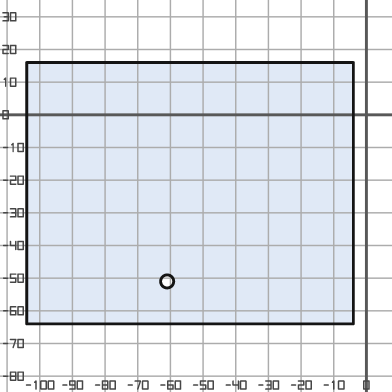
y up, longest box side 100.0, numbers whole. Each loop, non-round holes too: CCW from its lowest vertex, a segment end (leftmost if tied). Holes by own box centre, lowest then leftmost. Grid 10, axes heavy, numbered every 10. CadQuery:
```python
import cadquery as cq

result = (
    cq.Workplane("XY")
    .moveTo(-104.0, -64.0)
    .lineTo(-4.0, -64.0)
    .lineTo(-4.0, 16.0)
    .lineTo(-104.0, 16.0)
    .close()
    .moveTo(-61.0, -51.0)
    .circle(2.0)
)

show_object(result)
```